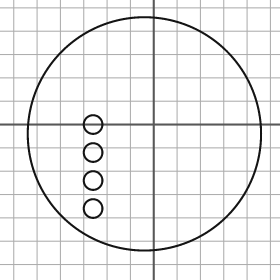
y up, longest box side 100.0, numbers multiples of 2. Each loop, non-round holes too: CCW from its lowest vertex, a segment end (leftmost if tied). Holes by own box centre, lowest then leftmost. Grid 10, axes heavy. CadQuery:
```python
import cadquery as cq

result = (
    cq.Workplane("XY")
    .moveTo(-4.0, -4.0)
    .circle(50.0)
    .moveTo(-26.0, -36.0)
    .circle(4.0)
    .moveTo(-26.0, -24.0)
    .circle(4.0)
    .moveTo(-26.0, -12.0)
    .circle(4.0)
    .moveTo(-26.0, 0.0)
    .circle(4.0)
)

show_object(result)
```